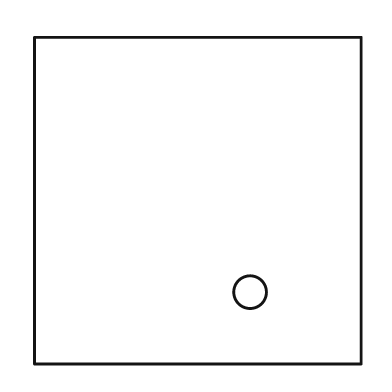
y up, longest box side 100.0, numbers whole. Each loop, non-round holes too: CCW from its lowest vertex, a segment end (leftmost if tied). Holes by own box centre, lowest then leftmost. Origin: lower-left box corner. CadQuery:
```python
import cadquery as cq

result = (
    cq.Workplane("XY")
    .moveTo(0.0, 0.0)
    .lineTo(100.0, 0.0)
    .lineTo(100.0, 100.0)
    .lineTo(0.0, 100.0)
    .close()
    .moveTo(66.0, 22.0)
    .circle(5.0)
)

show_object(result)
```